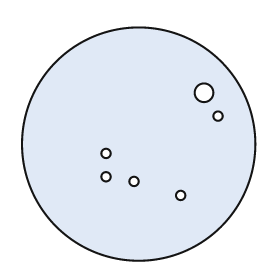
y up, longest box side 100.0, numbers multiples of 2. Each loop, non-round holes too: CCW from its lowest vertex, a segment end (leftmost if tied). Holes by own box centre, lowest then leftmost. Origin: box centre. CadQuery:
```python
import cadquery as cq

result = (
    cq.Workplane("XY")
    .moveTo(0.0, 0.0)
    .circle(50.0)
    .moveTo(18.0, -22.0)
    .circle(2.0)
    .moveTo(-2.0, -16.0)
    .circle(2.0)
    .moveTo(-14.0, -14.0)
    .circle(2.0)
    .moveTo(-14.0, -4.0)
    .circle(2.0)
    .moveTo(34.0, 12.0)
    .circle(2.0)
    .moveTo(28.0, 22.0)
    .circle(4.0)
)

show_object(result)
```